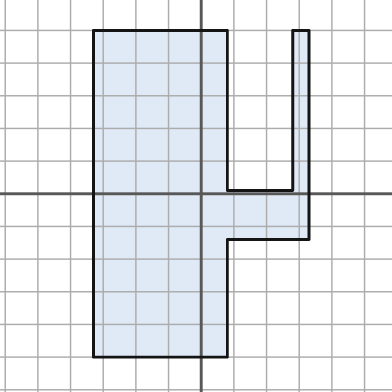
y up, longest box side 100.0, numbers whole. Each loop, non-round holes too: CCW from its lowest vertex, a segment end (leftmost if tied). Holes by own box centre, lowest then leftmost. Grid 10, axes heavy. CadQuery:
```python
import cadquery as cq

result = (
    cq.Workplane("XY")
    .moveTo(-33.0, -50.0)
    .lineTo(8.0, -50.0)
    .lineTo(8.0, -14.0)
    .lineTo(33.0, -14.0)
    .lineTo(33.0, 50.0)
    .lineTo(28.0, 50.0)
    .lineTo(28.0, 1.0)
    .lineTo(8.0, 1.0)
    .lineTo(8.0, 50.0)
    .lineTo(-33.0, 50.0)
    .close()
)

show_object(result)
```